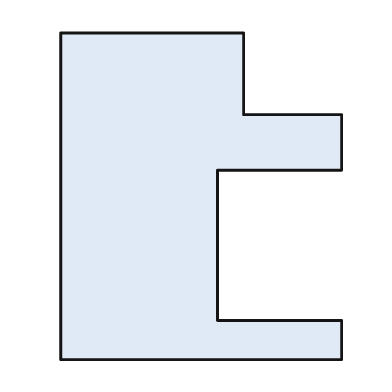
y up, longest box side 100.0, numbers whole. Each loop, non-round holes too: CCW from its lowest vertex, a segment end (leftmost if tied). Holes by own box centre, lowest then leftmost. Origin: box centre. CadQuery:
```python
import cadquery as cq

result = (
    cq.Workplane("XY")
    .moveTo(-43.0, -50.0)
    .lineTo(43.0, -50.0)
    .lineTo(43.0, -38.0)
    .lineTo(5.0, -38.0)
    .lineTo(5.0, 8.0)
    .lineTo(43.0, 8.0)
    .lineTo(43.0, 25.0)
    .lineTo(13.0, 25.0)
    .lineTo(13.0, 50.0)
    .lineTo(-43.0, 50.0)
    .close()
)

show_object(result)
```